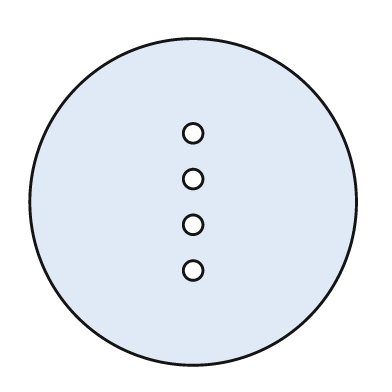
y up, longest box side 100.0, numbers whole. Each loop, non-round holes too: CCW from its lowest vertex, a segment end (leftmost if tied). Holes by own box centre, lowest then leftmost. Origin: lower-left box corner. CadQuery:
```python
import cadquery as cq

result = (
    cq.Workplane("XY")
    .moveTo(50.0, 50.0)
    .circle(50.0)
    .moveTo(50.0, 29.0)
    .circle(3.0)
    .moveTo(50.0, 43.0)
    .circle(3.0)
    .moveTo(50.0, 57.0)
    .circle(3.0)
    .moveTo(50.0, 71.0)
    .circle(3.0)
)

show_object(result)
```